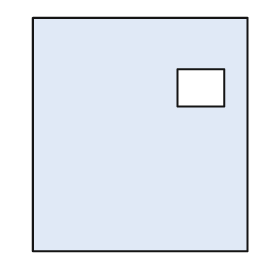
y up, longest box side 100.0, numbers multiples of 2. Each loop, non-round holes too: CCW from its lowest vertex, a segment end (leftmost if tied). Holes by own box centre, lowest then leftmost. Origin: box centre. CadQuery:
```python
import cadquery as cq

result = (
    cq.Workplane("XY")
    .moveTo(-46.0, -50.0)
    .lineTo(46.0, -50.0)
    .lineTo(46.0, 50.0)
    .lineTo(-46.0, 50.0)
    .close()
    .moveTo(16.0, 12.0)
    .lineTo(36.0, 12.0)
    .lineTo(36.0, 28.0)
    .lineTo(16.0, 28.0)
    .close()
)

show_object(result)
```